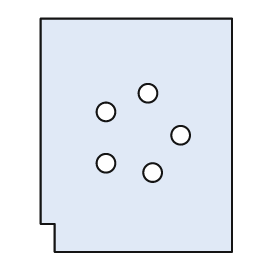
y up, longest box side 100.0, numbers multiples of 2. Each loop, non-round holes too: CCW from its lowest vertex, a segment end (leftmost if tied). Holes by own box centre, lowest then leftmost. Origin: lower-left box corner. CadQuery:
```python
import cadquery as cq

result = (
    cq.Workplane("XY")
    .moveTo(6.0, 0.0)
    .lineTo(82.0, 0.0)
    .lineTo(82.0, 100.0)
    .lineTo(0.0, 100.0)
    .lineTo(0.0, 12.0)
    .lineTo(6.0, 12.0)
    .close()
    .moveTo(48.0, 34.0)
    .circle(4.0)
    .moveTo(28.0, 38.0)
    .circle(4.0)
    .moveTo(60.0, 50.0)
    .circle(4.0)
    .moveTo(28.0, 60.0)
    .circle(4.0)
    .moveTo(46.0, 68.0)
    .circle(4.0)
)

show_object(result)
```